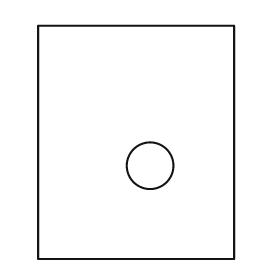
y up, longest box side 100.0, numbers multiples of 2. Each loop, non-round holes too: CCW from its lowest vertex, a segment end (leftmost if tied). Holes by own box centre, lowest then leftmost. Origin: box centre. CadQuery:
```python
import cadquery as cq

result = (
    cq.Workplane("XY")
    .moveTo(-42.0, -50.0)
    .lineTo(42.0, -50.0)
    .lineTo(42.0, 50.0)
    .lineTo(-42.0, 50.0)
    .close()
    .moveTo(6.0, -10.0)
    .circle(10.0)
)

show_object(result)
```